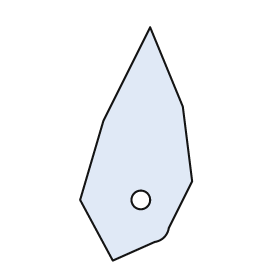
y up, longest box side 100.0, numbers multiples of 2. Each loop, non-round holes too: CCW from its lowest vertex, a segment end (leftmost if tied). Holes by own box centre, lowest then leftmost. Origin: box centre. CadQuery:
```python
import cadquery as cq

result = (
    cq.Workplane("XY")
    .moveTo(-10.0, -50.0)
    .lineTo(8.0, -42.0)
    .threePointArc((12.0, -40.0), (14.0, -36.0))
    .lineTo(24.0, -16.0)
    .lineTo(20.0, 16.0)
    .lineTo(6.0, 50.0)
    .lineTo(-14.0, 10.0)
    .lineTo(-24.0, -24.0)
    .close()
    .moveTo(2.0, -24.0)
    .circle(4.0)
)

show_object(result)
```